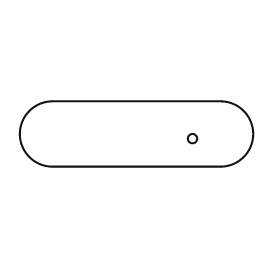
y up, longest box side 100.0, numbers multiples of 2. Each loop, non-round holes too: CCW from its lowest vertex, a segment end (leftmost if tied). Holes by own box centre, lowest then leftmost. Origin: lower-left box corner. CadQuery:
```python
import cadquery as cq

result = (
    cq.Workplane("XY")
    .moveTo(14.0, 0.0)
    .lineTo(86.0, 0.0)
    .threePointArc((100.0, 14.0), (86.0, 28.0))
    .lineTo(14.0, 28.0)
    .threePointArc((0.0, 14.0), (14.0, 0.0))
    .close()
    .moveTo(74.0, 12.0)
    .circle(2.0)
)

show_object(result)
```